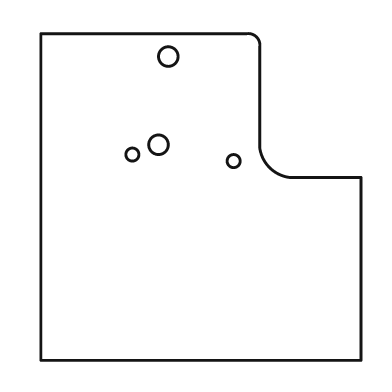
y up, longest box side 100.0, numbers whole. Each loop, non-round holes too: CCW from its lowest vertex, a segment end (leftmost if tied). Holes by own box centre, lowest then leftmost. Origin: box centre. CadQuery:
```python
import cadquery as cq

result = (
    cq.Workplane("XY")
    .moveTo(-49.0, -50.0)
    .lineTo(49.0, -50.0)
    .lineTo(49.0, 6.0)
    .lineTo(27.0, 6.0)
    .threePointArc((21.0, 9.0), (18.0, 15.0))
    .lineTo(18.0, 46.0)
    .threePointArc((17.0, 49.0), (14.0, 50.0))
    .lineTo(-49.0, 50.0)
    .close()
    .moveTo(10.0, 11.0)
    .circle(2.0)
    .moveTo(-21.0, 13.0)
    .circle(2.0)
    .moveTo(-13.0, 16.0)
    .circle(3.0)
    .moveTo(-10.0, 43.0)
    .circle(3.0)
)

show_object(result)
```